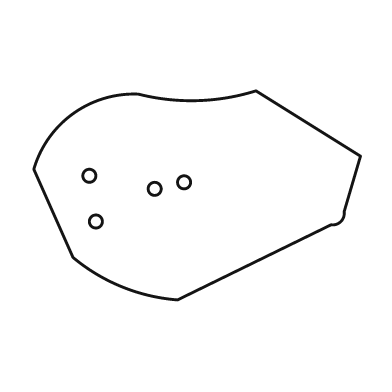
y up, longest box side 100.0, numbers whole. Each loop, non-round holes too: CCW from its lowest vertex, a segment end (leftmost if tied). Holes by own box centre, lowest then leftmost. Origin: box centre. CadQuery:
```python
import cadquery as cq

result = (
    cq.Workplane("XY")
    .moveTo(-6.0, -32.0)
    .lineTo(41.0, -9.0)
    .threePointArc((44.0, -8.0), (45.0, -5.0))
    .lineTo(50.0, 12.0)
    .lineTo(18.0, 32.0)
    .threePointArc((0.0, 29.0), (-18.0, 31.0))
    .threePointArc((-38.0, 25.0), (-50.0, 8.0))
    .lineTo(-38.0, -19.0)
    .threePointArc((-23.0, -28.0), (-6.0, -32.0))
    .close()
    .moveTo(-31.0, -8.0)
    .circle(2.0)
    .moveTo(-13.0, 2.0)
    .circle(2.0)
    .moveTo(-4.0, 4.0)
    .circle(2.0)
    .moveTo(-33.0, 6.0)
    .circle(2.0)
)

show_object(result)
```